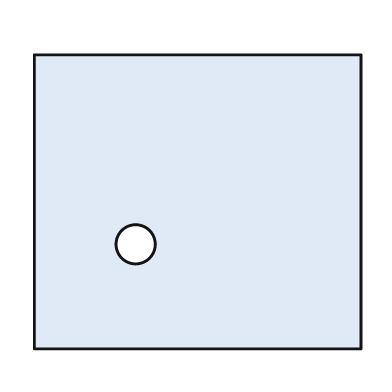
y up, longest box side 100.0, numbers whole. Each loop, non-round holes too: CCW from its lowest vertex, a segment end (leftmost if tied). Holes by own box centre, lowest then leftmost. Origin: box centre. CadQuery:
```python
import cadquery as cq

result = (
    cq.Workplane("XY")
    .moveTo(-50.0, -45.0)
    .lineTo(50.0, -45.0)
    .lineTo(50.0, 45.0)
    .lineTo(-50.0, 45.0)
    .close()
    .moveTo(-19.0, -13.0)
    .circle(6.0)
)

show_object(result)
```